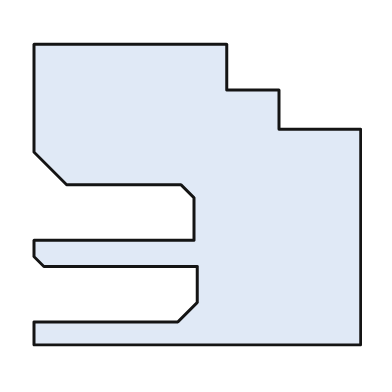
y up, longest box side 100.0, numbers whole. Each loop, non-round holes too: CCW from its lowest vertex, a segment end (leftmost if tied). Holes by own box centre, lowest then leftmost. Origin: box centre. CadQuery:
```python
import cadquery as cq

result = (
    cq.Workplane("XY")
    .moveTo(-50.0, -46.0)
    .lineTo(50.0, -46.0)
    .lineTo(50.0, 20.0)
    .lineTo(25.0, 20.0)
    .lineTo(25.0, 32.0)
    .lineTo(9.0, 32.0)
    .lineTo(9.0, 46.0)
    .lineTo(-50.0, 46.0)
    .lineTo(-50.0, 13.0)
    .lineTo(-40.0, 3.0)
    .lineTo(-5.0, 3.0)
    .lineTo(-1.0, -1.0)
    .lineTo(-1.0, -14.0)
    .lineTo(-50.0, -14.0)
    .lineTo(-50.0, -19.0)
    .lineTo(-47.0, -22.0)
    .lineTo(0.0, -22.0)
    .lineTo(0.0, -33.0)
    .lineTo(-6.0, -39.0)
    .lineTo(-50.0, -39.0)
    .close()
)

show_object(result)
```